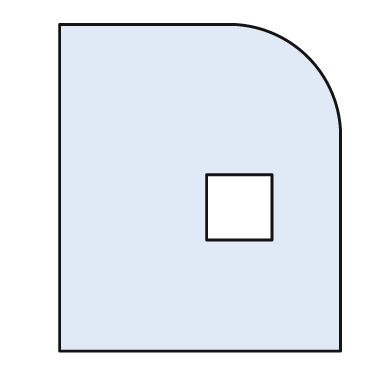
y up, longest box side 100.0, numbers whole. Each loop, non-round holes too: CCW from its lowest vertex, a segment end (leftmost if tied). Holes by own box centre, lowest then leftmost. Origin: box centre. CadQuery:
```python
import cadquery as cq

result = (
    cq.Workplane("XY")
    .moveTo(-43.0, -50.0)
    .lineTo(43.0, -50.0)
    .lineTo(43.0, 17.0)
    .threePointArc((33.0, 40.0), (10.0, 50.0))
    .lineTo(-43.0, 50.0)
    .close()
    .moveTo(2.0, -16.0)
    .lineTo(22.0, -16.0)
    .lineTo(22.0, 4.0)
    .lineTo(2.0, 4.0)
    .close()
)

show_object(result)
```